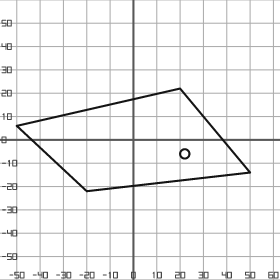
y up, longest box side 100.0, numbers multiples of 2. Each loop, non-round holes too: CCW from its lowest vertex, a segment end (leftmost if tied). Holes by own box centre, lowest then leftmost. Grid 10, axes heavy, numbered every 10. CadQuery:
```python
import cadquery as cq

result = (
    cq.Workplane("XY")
    .moveTo(-20.0, -22.0)
    .lineTo(50.0, -14.0)
    .lineTo(20.0, 22.0)
    .lineTo(-50.0, 6.0)
    .close()
    .moveTo(22.0, -6.0)
    .circle(2.0)
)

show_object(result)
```